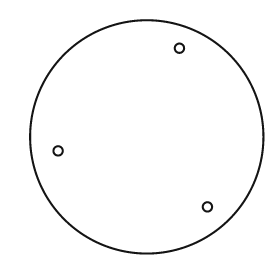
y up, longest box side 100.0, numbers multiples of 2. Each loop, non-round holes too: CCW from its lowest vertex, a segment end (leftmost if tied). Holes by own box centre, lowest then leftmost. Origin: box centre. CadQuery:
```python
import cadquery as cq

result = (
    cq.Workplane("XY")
    .moveTo(0.0, 0.0)
    .circle(50.0)
    .moveTo(26.0, -30.0)
    .circle(2.0)
    .moveTo(-38.0, -6.0)
    .circle(2.0)
    .moveTo(14.0, 38.0)
    .circle(2.0)
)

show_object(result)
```